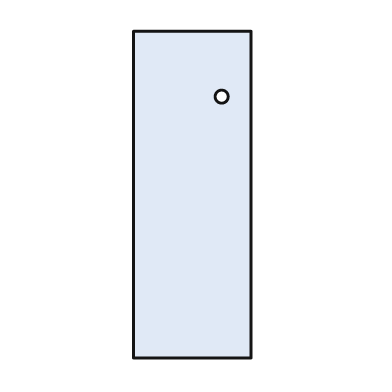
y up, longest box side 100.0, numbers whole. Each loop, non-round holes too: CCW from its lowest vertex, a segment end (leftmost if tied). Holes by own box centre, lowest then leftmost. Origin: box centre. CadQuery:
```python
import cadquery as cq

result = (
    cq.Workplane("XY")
    .moveTo(-18.0, -50.0)
    .lineTo(18.0, -50.0)
    .lineTo(18.0, 50.0)
    .lineTo(-18.0, 50.0)
    .close()
    .moveTo(9.0, 30.0)
    .circle(2.0)
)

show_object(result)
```